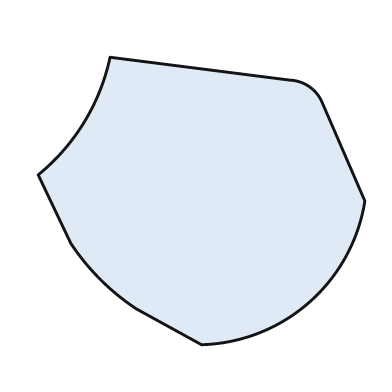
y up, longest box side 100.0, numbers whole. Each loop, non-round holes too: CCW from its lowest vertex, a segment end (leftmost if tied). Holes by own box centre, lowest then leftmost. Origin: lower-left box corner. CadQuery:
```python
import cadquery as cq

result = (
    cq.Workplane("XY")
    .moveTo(50.0, 0.0)
    .threePointArc((83.0, 13.0), (100.0, 44.0))
    .lineTo(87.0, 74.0)
    .threePointArc((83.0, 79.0), (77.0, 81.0))
    .lineTo(22.0, 88.0)
    .threePointArc((14.0, 68.0), (0.0, 52.0))
    .lineTo(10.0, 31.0)
    .threePointArc((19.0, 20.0), (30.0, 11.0))
    .close()
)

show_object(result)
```